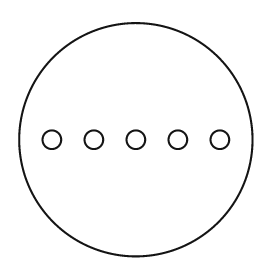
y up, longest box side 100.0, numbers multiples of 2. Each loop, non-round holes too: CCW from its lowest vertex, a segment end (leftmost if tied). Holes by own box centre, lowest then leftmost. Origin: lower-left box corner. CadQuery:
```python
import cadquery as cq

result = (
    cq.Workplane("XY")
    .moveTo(50.0, 50.0)
    .circle(50.0)
    .moveTo(14.0, 50.0)
    .circle(4.0)
    .moveTo(32.0, 50.0)
    .circle(4.0)
    .moveTo(50.0, 50.0)
    .circle(4.0)
    .moveTo(68.0, 50.0)
    .circle(4.0)
    .moveTo(86.0, 50.0)
    .circle(4.0)
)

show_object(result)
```